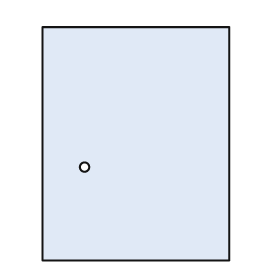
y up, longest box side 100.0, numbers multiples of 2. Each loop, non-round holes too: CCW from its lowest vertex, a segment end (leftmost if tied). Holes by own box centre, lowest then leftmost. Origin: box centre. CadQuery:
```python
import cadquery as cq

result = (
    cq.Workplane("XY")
    .moveTo(-40.0, -50.0)
    .lineTo(40.0, -50.0)
    .lineTo(40.0, 50.0)
    .lineTo(-40.0, 50.0)
    .close()
    .moveTo(-22.0, -10.0)
    .circle(2.0)
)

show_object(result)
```